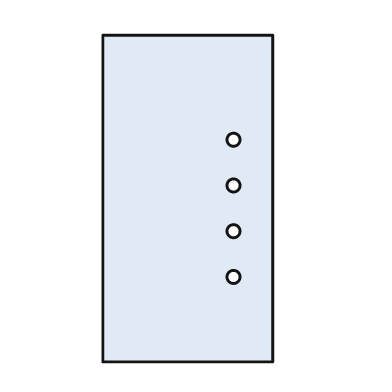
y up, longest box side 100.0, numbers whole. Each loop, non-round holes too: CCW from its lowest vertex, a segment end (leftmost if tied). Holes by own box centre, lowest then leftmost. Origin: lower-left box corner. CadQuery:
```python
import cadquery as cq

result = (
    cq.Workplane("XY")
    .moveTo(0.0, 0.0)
    .lineTo(52.0, 0.0)
    .lineTo(52.0, 100.0)
    .lineTo(0.0, 100.0)
    .close()
    .moveTo(40.0, 26.0)
    .circle(2.0)
    .moveTo(40.0, 40.0)
    .circle(2.0)
    .moveTo(40.0, 54.0)
    .circle(2.0)
    .moveTo(40.0, 68.0)
    .circle(2.0)
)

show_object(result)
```